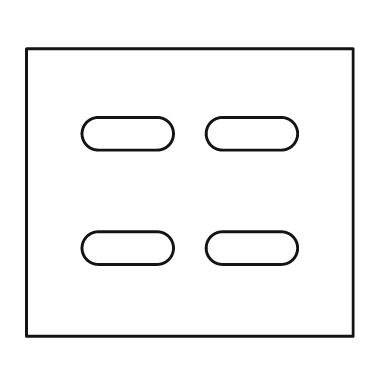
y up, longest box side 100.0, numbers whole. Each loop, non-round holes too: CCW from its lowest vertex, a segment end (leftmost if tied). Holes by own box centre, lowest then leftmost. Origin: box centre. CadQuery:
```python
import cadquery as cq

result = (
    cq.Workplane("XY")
    .moveTo(-50.0, -44.0)
    .lineTo(50.0, -44.0)
    .lineTo(50.0, 44.0)
    .lineTo(-50.0, 44.0)
    .close()
    .moveTo(-28.0, -22.0)
    .lineTo(-10.0, -22.0)
    .threePointArc((-5.0, -17.0), (-10.0, -12.0))
    .lineTo(-28.0, -12.0)
    .threePointArc((-33.0, -17.0), (-28.0, -22.0))
    .close()
    .moveTo(10.0, -22.0)
    .lineTo(28.0, -22.0)
    .threePointArc((33.0, -17.0), (28.0, -12.0))
    .lineTo(10.0, -12.0)
    .threePointArc((5.0, -17.0), (10.0, -22.0))
    .close()
    .moveTo(-28.0, 13.0)
    .lineTo(-10.0, 13.0)
    .threePointArc((-5.0, 18.0), (-10.0, 23.0))
    .lineTo(-28.0, 23.0)
    .threePointArc((-33.0, 18.0), (-28.0, 13.0))
    .close()
    .moveTo(10.0, 13.0)
    .lineTo(28.0, 13.0)
    .threePointArc((33.0, 18.0), (28.0, 23.0))
    .lineTo(10.0, 23.0)
    .threePointArc((5.0, 18.0), (10.0, 13.0))
    .close()
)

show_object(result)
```